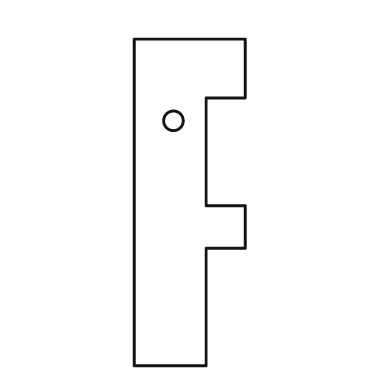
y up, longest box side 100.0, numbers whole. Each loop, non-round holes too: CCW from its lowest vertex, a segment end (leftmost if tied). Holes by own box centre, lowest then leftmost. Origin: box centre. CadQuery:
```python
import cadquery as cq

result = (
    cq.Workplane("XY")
    .moveTo(-17.0, -50.0)
    .lineTo(5.0, -50.0)
    .lineTo(5.0, -14.0)
    .lineTo(17.0, -14.0)
    .lineTo(17.0, -1.0)
    .lineTo(5.0, -1.0)
    .lineTo(5.0, 32.0)
    .lineTo(17.0, 32.0)
    .lineTo(17.0, 50.0)
    .lineTo(-17.0, 50.0)
    .close()
    .moveTo(-5.0, 25.0)
    .circle(3.0)
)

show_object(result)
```